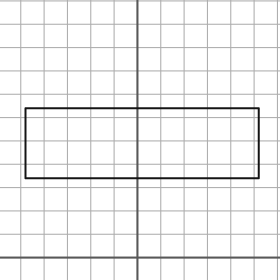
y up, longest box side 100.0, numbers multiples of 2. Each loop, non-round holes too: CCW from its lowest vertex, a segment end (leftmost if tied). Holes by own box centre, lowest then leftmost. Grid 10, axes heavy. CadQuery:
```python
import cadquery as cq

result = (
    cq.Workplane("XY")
    .moveTo(-48.0, 34.0)
    .lineTo(52.0, 34.0)
    .lineTo(52.0, 64.0)
    .lineTo(-48.0, 64.0)
    .close()
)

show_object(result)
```